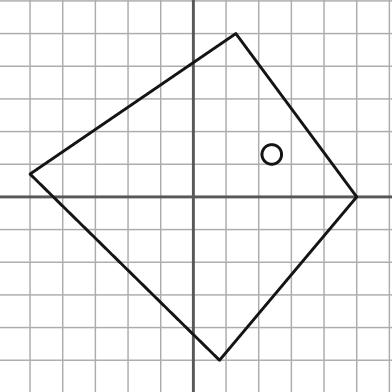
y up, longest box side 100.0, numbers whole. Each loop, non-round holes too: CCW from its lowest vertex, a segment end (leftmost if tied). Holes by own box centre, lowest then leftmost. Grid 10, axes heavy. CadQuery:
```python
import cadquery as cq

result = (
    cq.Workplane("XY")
    .moveTo(8.0, -50.0)
    .lineTo(50.0, 0.0)
    .lineTo(13.0, 50.0)
    .lineTo(-50.0, 7.0)
    .close()
    .moveTo(24.0, 13.0)
    .circle(3.0)
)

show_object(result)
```